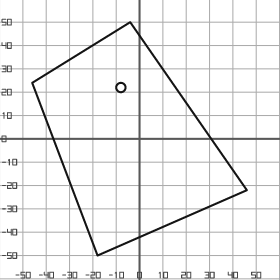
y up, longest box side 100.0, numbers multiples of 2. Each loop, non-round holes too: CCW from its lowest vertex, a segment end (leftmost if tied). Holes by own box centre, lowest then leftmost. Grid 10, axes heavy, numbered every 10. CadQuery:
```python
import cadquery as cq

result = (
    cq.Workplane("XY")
    .moveTo(-18.0, -50.0)
    .lineTo(46.0, -22.0)
    .lineTo(-4.0, 50.0)
    .lineTo(-46.0, 24.0)
    .close()
    .moveTo(-8.0, 22.0)
    .circle(2.0)
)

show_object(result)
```